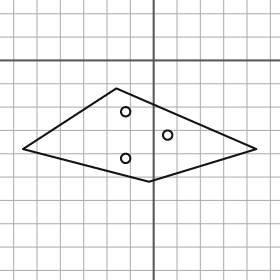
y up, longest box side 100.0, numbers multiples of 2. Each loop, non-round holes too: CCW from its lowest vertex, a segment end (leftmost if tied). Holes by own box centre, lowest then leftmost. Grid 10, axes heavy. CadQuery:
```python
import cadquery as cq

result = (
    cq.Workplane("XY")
    .moveTo(-2.0, -52.0)
    .lineTo(44.0, -38.0)
    .lineTo(-16.0, -12.0)
    .lineTo(-56.0, -38.0)
    .close()
    .moveTo(-12.0, -42.0)
    .circle(2.0)
    .moveTo(6.0, -32.0)
    .circle(2.0)
    .moveTo(-12.0, -22.0)
    .circle(2.0)
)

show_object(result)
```